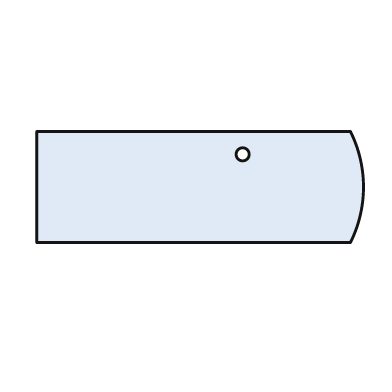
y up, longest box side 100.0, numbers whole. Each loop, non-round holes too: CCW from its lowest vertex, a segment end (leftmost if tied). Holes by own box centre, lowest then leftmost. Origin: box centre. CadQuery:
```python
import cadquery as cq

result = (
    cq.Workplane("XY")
    .moveTo(-50.0, -17.0)
    .lineTo(46.0, -17.0)
    .threePointArc((50.0, 0.0), (46.0, 17.0))
    .lineTo(-50.0, 17.0)
    .close()
    .moveTo(13.0, 10.0)
    .circle(2.0)
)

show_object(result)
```